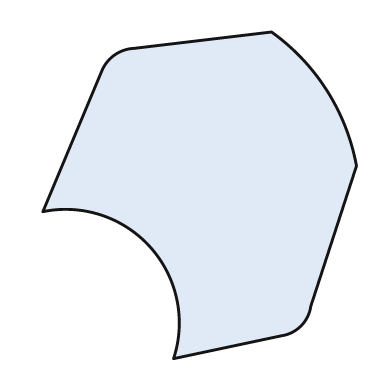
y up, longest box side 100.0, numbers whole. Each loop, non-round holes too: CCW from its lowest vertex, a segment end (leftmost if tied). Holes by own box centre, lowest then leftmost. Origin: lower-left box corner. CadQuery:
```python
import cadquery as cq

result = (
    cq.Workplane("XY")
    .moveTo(40.0, 0.0)
    .lineTo(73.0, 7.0)
    .threePointArc((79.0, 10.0), (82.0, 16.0))
    .lineTo(96.0, 59.0)
    .threePointArc((87.0, 82.0), (70.0, 100.0))
    .lineTo(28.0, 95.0)
    .threePointArc((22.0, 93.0), (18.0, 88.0))
    .lineTo(0.0, 45.0)
    .threePointArc((33.0, 34.0), (40.0, 0.0))
    .close()
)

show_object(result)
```